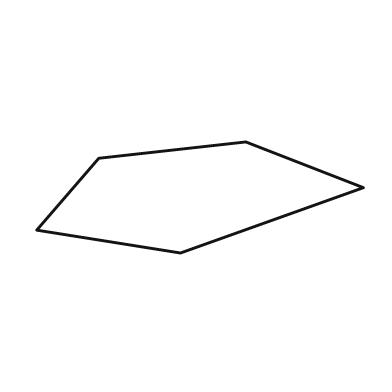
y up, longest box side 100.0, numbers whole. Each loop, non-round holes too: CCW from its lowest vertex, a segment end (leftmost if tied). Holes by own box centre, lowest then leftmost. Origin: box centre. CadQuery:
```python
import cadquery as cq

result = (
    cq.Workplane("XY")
    .moveTo(-6.0, -17.0)
    .lineTo(50.0, 3.0)
    .lineTo(14.0, 17.0)
    .lineTo(-31.0, 12.0)
    .lineTo(-50.0, -10.0)
    .close()
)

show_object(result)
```